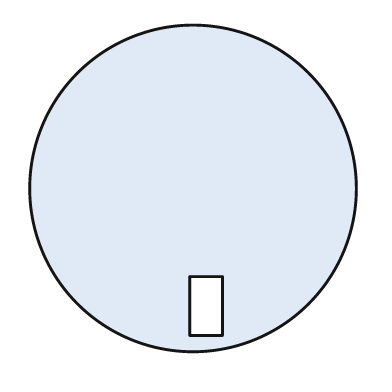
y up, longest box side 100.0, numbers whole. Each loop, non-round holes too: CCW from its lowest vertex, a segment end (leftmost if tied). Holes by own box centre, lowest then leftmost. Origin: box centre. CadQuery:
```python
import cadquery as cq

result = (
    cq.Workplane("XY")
    .moveTo(0.0, 0.0)
    .circle(50.0)
    .moveTo(-1.0, -45.0)
    .lineTo(9.0, -45.0)
    .lineTo(9.0, -27.0)
    .lineTo(-1.0, -27.0)
    .close()
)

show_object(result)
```